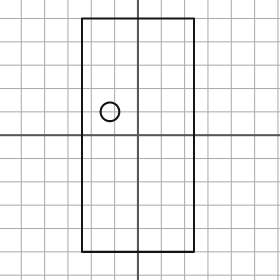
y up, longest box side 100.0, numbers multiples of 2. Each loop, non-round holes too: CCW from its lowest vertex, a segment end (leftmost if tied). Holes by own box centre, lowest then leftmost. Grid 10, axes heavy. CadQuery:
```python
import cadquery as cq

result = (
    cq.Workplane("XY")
    .moveTo(-24.0, -50.0)
    .lineTo(24.0, -50.0)
    .lineTo(24.0, 50.0)
    .lineTo(-24.0, 50.0)
    .close()
    .moveTo(-12.0, 10.0)
    .circle(4.0)
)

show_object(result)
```